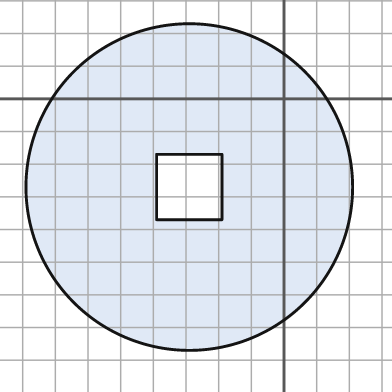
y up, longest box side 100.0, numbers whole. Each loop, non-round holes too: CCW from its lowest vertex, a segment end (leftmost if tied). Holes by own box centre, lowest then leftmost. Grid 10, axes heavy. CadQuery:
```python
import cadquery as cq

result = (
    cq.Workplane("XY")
    .moveTo(-29.0, -27.0)
    .circle(50.0)
    .moveTo(-39.0, -37.0)
    .lineTo(-19.0, -37.0)
    .lineTo(-19.0, -17.0)
    .lineTo(-39.0, -17.0)
    .close()
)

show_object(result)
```